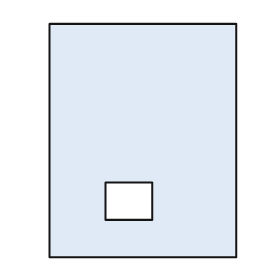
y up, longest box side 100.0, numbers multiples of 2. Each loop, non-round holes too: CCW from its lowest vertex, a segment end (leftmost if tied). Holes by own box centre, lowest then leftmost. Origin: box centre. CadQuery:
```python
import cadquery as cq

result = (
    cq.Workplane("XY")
    .moveTo(-40.0, -50.0)
    .lineTo(40.0, -50.0)
    .lineTo(40.0, 50.0)
    .lineTo(-40.0, 50.0)
    .close()
    .moveTo(-16.0, -34.0)
    .lineTo(4.0, -34.0)
    .lineTo(4.0, -18.0)
    .lineTo(-16.0, -18.0)
    .close()
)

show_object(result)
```